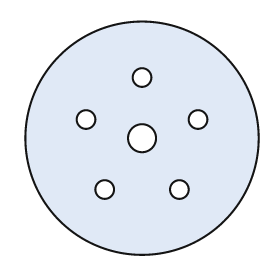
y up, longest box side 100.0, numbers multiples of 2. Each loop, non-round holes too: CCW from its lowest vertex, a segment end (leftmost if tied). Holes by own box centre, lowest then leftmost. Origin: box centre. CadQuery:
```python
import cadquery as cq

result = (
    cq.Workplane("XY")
    .moveTo(0.0, 0.0)
    .circle(50.0)
    .moveTo(-16.0, -22.0)
    .circle(4.0)
    .moveTo(16.0, -22.0)
    .circle(4.0)
    .moveTo(0.0, 0.0)
    .circle(6.0)
    .moveTo(-24.0, 8.0)
    .circle(4.0)
    .moveTo(24.0, 8.0)
    .circle(4.0)
    .moveTo(0.0, 26.0)
    .circle(4.0)
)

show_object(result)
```